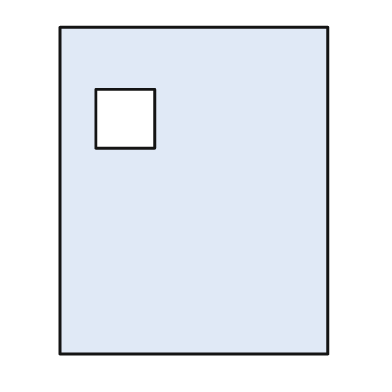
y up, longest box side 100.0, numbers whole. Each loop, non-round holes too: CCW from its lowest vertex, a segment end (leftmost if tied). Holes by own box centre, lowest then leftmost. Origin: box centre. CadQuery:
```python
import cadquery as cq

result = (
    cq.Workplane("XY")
    .moveTo(-41.0, -50.0)
    .lineTo(41.0, -50.0)
    .lineTo(41.0, 50.0)
    .lineTo(-41.0, 50.0)
    .close()
    .moveTo(-30.0, 13.0)
    .lineTo(-12.0, 13.0)
    .lineTo(-12.0, 31.0)
    .lineTo(-30.0, 31.0)
    .close()
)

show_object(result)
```